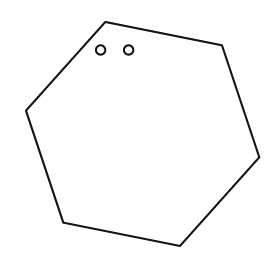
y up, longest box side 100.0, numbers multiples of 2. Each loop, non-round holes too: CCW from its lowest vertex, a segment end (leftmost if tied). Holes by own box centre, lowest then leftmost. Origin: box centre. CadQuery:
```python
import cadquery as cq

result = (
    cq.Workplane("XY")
    .moveTo(16.0, -48.0)
    .lineTo(50.0, -10.0)
    .lineTo(34.0, 38.0)
    .lineTo(-16.0, 48.0)
    .lineTo(-50.0, 10.0)
    .lineTo(-34.0, -38.0)
    .close()
    .moveTo(-18.0, 36.0)
    .circle(2.0)
    .moveTo(-6.0, 36.0)
    .circle(2.0)
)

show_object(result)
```